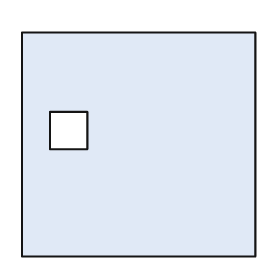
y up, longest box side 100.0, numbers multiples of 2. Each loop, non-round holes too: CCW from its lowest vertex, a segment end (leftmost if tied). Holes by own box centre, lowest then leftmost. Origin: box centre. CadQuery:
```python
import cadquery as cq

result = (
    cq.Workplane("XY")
    .moveTo(-50.0, -48.0)
    .lineTo(50.0, -48.0)
    .lineTo(50.0, 48.0)
    .lineTo(-50.0, 48.0)
    .close()
    .moveTo(-38.0, -2.0)
    .lineTo(-22.0, -2.0)
    .lineTo(-22.0, 14.0)
    .lineTo(-38.0, 14.0)
    .close()
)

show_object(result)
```